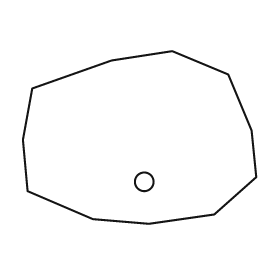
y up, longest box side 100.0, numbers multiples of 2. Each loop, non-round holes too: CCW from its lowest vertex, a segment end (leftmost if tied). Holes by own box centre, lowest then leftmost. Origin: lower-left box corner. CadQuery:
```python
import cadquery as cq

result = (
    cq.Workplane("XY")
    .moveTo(54.0, 0.0)
    .lineTo(82.0, 4.0)
    .lineTo(100.0, 20.0)
    .lineTo(98.0, 40.0)
    .lineTo(88.0, 64.0)
    .lineTo(64.0, 74.0)
    .lineTo(38.0, 70.0)
    .lineTo(4.0, 58.0)
    .lineTo(0.0, 36.0)
    .lineTo(2.0, 14.0)
    .lineTo(30.0, 2.0)
    .close()
    .moveTo(52.0, 18.0)
    .circle(4.0)
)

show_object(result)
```